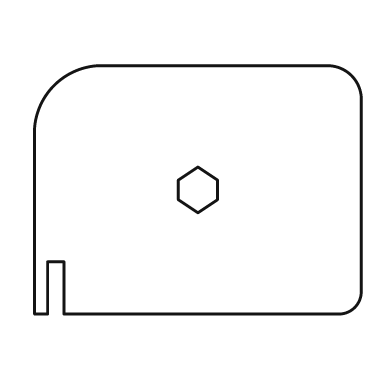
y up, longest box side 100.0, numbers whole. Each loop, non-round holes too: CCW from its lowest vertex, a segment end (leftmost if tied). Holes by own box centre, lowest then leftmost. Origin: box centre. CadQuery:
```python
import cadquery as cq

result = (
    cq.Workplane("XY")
    .moveTo(-50.0, -38.0)
    .lineTo(-46.0, -38.0)
    .lineTo(-46.0, -22.0)
    .lineTo(-41.0, -22.0)
    .lineTo(-41.0, -38.0)
    .lineTo(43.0, -38.0)
    .threePointArc((48.0, -36.0), (50.0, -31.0))
    .lineTo(50.0, 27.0)
    .threePointArc((47.0, 35.0), (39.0, 38.0))
    .lineTo(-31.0, 38.0)
    .threePointArc((-44.0, 32.0), (-50.0, 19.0))
    .close()
    .moveTo(0.0, -7.0)
    .lineTo(6.0, -3.0)
    .lineTo(6.0, 3.0)
    .lineTo(0.0, 7.0)
    .lineTo(-6.0, 3.0)
    .lineTo(-6.0, -3.0)
    .close()
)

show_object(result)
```